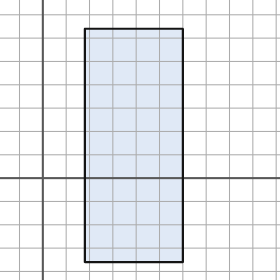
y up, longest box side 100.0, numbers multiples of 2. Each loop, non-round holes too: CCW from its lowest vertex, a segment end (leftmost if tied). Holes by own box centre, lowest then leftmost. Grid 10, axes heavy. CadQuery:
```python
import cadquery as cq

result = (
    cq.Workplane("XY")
    .moveTo(18.0, -36.0)
    .lineTo(60.0, -36.0)
    .lineTo(60.0, 64.0)
    .lineTo(18.0, 64.0)
    .close()
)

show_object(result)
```